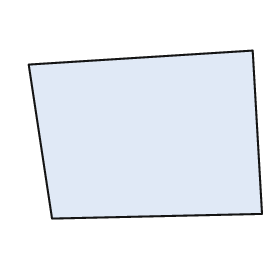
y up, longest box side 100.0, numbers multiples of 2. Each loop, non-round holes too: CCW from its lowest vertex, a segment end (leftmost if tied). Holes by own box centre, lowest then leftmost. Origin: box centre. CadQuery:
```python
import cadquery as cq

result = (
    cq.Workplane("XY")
    .moveTo(-40.0, -36.0)
    .lineTo(50.0, -34.0)
    .lineTo(46.0, 36.0)
    .lineTo(-50.0, 30.0)
    .close()
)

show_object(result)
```